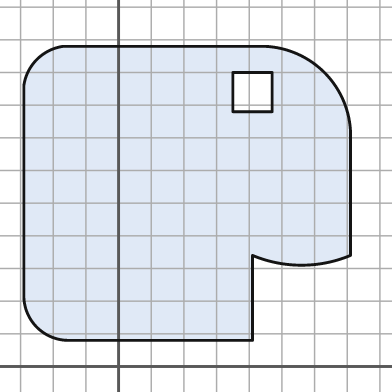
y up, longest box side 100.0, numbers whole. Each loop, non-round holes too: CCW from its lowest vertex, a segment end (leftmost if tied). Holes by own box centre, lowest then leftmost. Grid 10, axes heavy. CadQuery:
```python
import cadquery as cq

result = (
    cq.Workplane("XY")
    .moveTo(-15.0, 8.0)
    .lineTo(41.0, 8.0)
    .lineTo(41.0, 34.0)
    .threePointArc((56.0, 31.0), (71.0, 34.0))
    .lineTo(71.0, 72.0)
    .threePointArc((63.0, 90.0), (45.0, 98.0))
    .lineTo(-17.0, 98.0)
    .threePointArc((-25.0, 94.0), (-29.0, 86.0))
    .lineTo(-29.0, 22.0)
    .threePointArc((-25.0, 12.0), (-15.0, 8.0))
    .close()
    .moveTo(35.0, 78.0)
    .lineTo(47.0, 78.0)
    .lineTo(47.0, 90.0)
    .lineTo(35.0, 90.0)
    .close()
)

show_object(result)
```